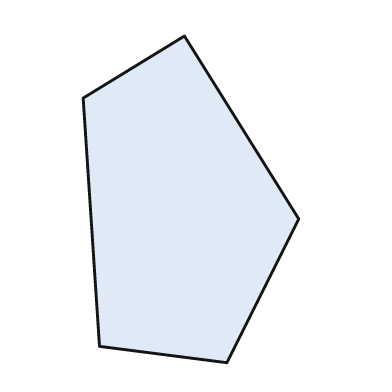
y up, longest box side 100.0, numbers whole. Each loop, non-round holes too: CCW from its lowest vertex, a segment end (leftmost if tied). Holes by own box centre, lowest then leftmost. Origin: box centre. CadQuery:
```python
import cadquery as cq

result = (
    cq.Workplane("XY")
    .moveTo(11.0, -50.0)
    .lineTo(33.0, -6.0)
    .lineTo(-2.0, 50.0)
    .lineTo(-33.0, 31.0)
    .lineTo(-28.0, -45.0)
    .close()
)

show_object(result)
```